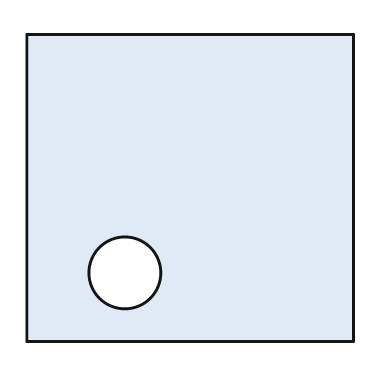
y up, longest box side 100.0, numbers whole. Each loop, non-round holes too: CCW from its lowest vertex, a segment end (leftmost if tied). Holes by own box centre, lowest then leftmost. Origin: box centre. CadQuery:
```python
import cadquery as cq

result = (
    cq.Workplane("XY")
    .moveTo(-50.0, -47.0)
    .lineTo(50.0, -47.0)
    .lineTo(50.0, 47.0)
    .lineTo(-50.0, 47.0)
    .close()
    .moveTo(-20.0, -26.0)
    .circle(11.0)
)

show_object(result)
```